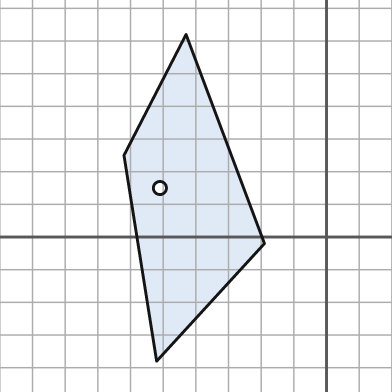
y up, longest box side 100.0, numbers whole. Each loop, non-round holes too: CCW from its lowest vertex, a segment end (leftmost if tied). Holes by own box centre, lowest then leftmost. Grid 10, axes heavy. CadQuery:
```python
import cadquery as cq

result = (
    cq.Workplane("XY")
    .moveTo(-52.0, -38.0)
    .lineTo(-19.0, -2.0)
    .lineTo(-43.0, 62.0)
    .lineTo(-62.0, 25.0)
    .close()
    .moveTo(-51.0, 15.0)
    .circle(2.0)
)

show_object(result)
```